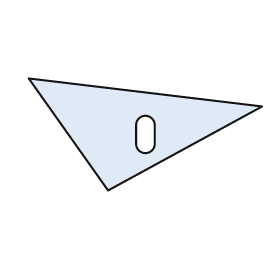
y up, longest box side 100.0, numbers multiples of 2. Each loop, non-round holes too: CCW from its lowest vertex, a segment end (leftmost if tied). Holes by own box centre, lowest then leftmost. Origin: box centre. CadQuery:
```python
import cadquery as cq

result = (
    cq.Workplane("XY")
    .moveTo(-16.0, -24.0)
    .lineTo(50.0, 12.0)
    .lineTo(-50.0, 24.0)
    .close()
    .moveTo(-4.0, -4.0)
    .threePointArc((0.0, -8.0), (4.0, -4.0))
    .lineTo(4.0, 4.0)
    .threePointArc((0.0, 8.0), (-4.0, 4.0))
    .close()
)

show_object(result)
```